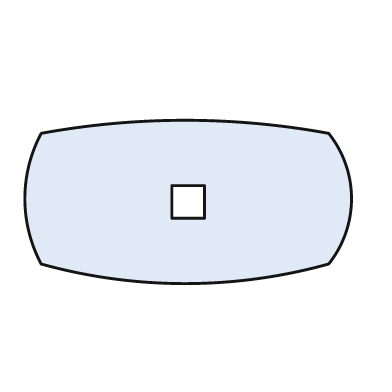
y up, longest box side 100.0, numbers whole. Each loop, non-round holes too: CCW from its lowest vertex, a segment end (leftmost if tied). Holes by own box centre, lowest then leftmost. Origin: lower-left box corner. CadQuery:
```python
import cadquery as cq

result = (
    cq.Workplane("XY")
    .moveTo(5.0, 6.0)
    .threePointArc((49.0, 0.0), (93.0, 6.0))
    .threePointArc((100.0, 26.0), (93.0, 46.0))
    .threePointArc((49.0, 50.0), (5.0, 46.0))
    .threePointArc((0.0, 26.0), (5.0, 6.0))
    .close()
    .moveTo(45.0, 20.0)
    .lineTo(55.0, 20.0)
    .lineTo(55.0, 30.0)
    .lineTo(45.0, 30.0)
    .close()
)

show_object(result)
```